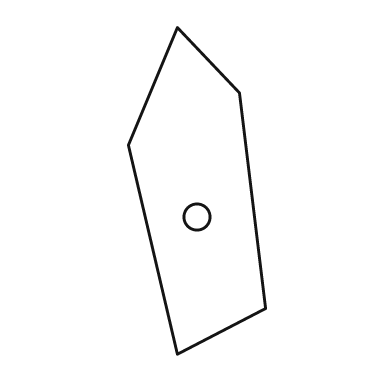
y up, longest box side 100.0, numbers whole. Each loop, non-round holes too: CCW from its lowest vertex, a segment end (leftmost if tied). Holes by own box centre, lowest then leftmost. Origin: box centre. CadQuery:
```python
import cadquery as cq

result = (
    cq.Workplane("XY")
    .moveTo(-6.0, -50.0)
    .lineTo(21.0, -36.0)
    .lineTo(13.0, 30.0)
    .lineTo(-6.0, 50.0)
    .lineTo(-21.0, 14.0)
    .close()
    .moveTo(0.0, -8.0)
    .circle(4.0)
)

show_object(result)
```